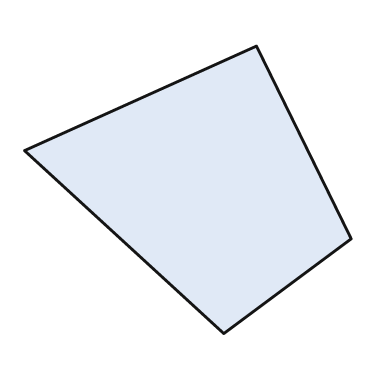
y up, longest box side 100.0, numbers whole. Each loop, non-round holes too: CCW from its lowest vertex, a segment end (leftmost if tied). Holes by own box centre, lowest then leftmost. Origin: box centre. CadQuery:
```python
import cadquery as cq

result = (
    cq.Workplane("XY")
    .moveTo(11.0, -44.0)
    .lineTo(50.0, -15.0)
    .lineTo(21.0, 44.0)
    .lineTo(-50.0, 12.0)
    .close()
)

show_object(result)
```